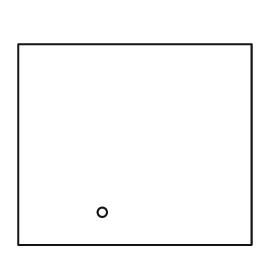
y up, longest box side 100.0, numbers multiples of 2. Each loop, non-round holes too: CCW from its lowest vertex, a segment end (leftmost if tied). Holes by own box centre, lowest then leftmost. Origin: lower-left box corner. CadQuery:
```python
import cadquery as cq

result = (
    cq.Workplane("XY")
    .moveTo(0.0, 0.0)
    .lineTo(100.0, 0.0)
    .lineTo(100.0, 86.0)
    .lineTo(0.0, 86.0)
    .close()
    .moveTo(36.0, 14.0)
    .circle(2.0)
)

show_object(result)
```